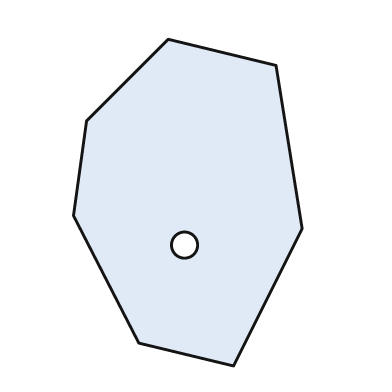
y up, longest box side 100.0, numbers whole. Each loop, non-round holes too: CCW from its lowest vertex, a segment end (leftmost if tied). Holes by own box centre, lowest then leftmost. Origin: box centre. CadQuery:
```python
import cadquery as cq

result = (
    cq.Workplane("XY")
    .moveTo(14.0, -50.0)
    .lineTo(35.0, -8.0)
    .lineTo(27.0, 42.0)
    .lineTo(-6.0, 50.0)
    .lineTo(-31.0, 25.0)
    .lineTo(-35.0, -4.0)
    .lineTo(-15.0, -43.0)
    .close()
    .moveTo(-1.0, -13.0)
    .circle(4.0)
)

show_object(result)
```